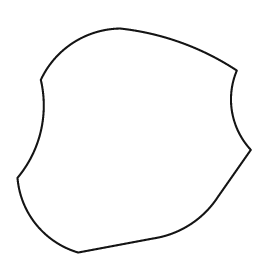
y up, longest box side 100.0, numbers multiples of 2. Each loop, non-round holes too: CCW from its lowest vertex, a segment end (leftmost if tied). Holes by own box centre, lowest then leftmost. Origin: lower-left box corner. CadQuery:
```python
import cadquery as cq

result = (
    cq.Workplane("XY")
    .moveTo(26.0, 0.0)
    .lineTo(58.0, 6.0)
    .threePointArc((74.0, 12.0), (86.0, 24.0))
    .lineTo(100.0, 44.0)
    .threePointArc((92.0, 60.0), (94.0, 78.0))
    .threePointArc((70.0, 90.0), (44.0, 96.0))
    .threePointArc((24.0, 90.0), (10.0, 74.0))
    .threePointArc((10.0, 52.0), (0.0, 32.0))
    .threePointArc((8.0, 12.0), (26.0, 0.0))
    .close()
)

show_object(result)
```